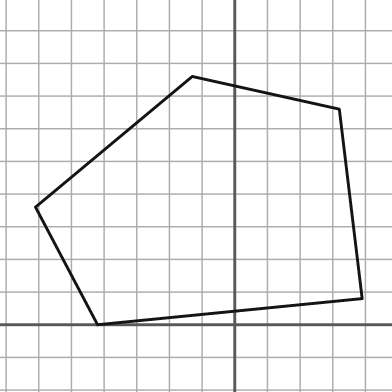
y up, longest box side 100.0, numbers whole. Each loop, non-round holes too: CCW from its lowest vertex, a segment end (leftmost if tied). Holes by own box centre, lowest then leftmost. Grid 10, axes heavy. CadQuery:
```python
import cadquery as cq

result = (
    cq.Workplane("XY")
    .moveTo(-42.0, 0.0)
    .lineTo(39.0, 8.0)
    .lineTo(32.0, 66.0)
    .lineTo(-13.0, 76.0)
    .lineTo(-61.0, 36.0)
    .close()
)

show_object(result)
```